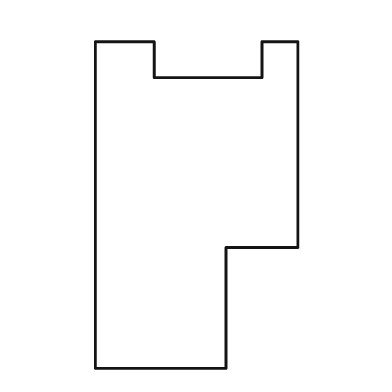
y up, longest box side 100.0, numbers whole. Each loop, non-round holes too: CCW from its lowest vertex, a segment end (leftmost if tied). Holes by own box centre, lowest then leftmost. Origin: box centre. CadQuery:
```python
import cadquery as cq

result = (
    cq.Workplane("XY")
    .moveTo(-31.0, -50.0)
    .lineTo(9.0, -50.0)
    .lineTo(9.0, -13.0)
    .lineTo(31.0, -13.0)
    .lineTo(31.0, 50.0)
    .lineTo(20.0, 50.0)
    .lineTo(20.0, 39.0)
    .lineTo(-13.0, 39.0)
    .lineTo(-13.0, 50.0)
    .lineTo(-31.0, 50.0)
    .close()
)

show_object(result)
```